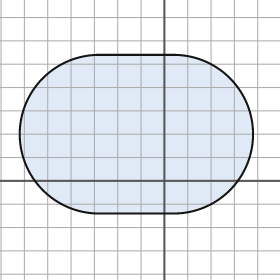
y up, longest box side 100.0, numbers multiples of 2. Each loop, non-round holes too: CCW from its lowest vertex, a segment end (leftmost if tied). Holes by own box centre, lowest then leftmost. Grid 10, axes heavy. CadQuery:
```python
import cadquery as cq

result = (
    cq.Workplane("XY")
    .moveTo(-28.0, -14.0)
    .lineTo(4.0, -14.0)
    .threePointArc((38.0, 20.0), (4.0, 54.0))
    .lineTo(-28.0, 54.0)
    .threePointArc((-62.0, 20.0), (-28.0, -14.0))
    .close()
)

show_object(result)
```